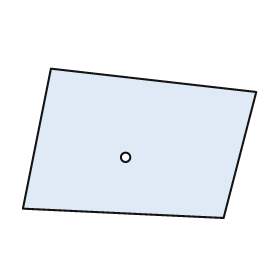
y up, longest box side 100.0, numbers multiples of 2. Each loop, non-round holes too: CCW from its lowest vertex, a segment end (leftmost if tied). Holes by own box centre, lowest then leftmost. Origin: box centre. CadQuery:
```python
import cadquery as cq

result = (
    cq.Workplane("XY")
    .moveTo(36.0, -32.0)
    .lineTo(50.0, 22.0)
    .lineTo(-38.0, 32.0)
    .lineTo(-50.0, -28.0)
    .close()
    .moveTo(-6.0, -6.0)
    .circle(2.0)
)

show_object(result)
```